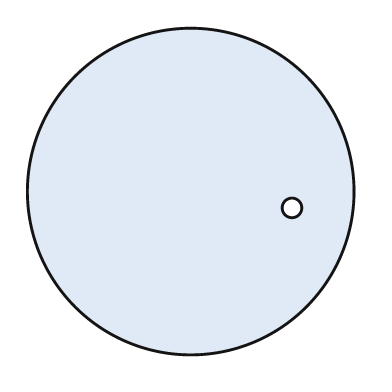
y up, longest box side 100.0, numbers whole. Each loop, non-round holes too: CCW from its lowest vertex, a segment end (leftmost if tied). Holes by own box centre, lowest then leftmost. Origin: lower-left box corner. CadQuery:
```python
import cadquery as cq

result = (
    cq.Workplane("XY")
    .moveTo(50.0, 50.0)
    .circle(50.0)
    .moveTo(81.0, 45.0)
    .circle(3.0)
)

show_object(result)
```